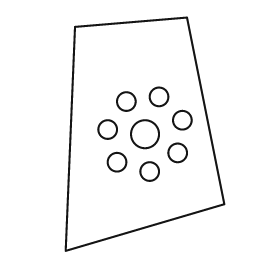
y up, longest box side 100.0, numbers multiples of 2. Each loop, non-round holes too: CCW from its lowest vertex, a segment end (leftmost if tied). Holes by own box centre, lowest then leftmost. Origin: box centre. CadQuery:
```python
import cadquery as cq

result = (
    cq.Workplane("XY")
    .moveTo(-34.0, -50.0)
    .lineTo(34.0, -30.0)
    .lineTo(18.0, 50.0)
    .lineTo(-30.0, 46.0)
    .close()
    .moveTo(2.0, -16.0)
    .circle(4.0)
    .moveTo(-12.0, -12.0)
    .circle(4.0)
    .moveTo(14.0, -8.0)
    .circle(4.0)
    .moveTo(0.0, 0.0)
    .circle(6.0)
    .moveTo(-16.0, 2.0)
    .circle(4.0)
    .moveTo(16.0, 6.0)
    .circle(4.0)
    .moveTo(-8.0, 14.0)
    .circle(4.0)
    .moveTo(6.0, 16.0)
    .circle(4.0)
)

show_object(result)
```